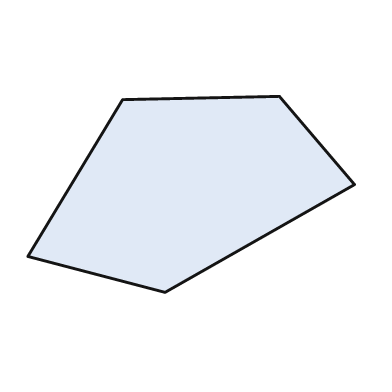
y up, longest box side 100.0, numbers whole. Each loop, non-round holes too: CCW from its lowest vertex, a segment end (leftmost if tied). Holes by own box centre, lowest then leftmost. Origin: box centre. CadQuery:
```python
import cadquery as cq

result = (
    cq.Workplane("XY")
    .moveTo(-8.0, -30.0)
    .lineTo(50.0, 3.0)
    .lineTo(27.0, 30.0)
    .lineTo(-21.0, 29.0)
    .lineTo(-50.0, -19.0)
    .close()
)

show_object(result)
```